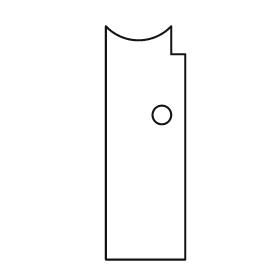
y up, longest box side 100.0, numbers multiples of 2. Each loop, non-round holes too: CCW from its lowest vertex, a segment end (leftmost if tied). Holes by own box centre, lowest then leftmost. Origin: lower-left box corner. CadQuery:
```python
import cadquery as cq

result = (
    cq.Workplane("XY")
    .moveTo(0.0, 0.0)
    .lineTo(34.0, 0.0)
    .lineTo(34.0, 88.0)
    .lineTo(28.0, 88.0)
    .lineTo(28.0, 100.0)
    .threePointArc((14.0, 94.0), (0.0, 100.0))
    .close()
    .moveTo(24.0, 62.0)
    .circle(4.0)
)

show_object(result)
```